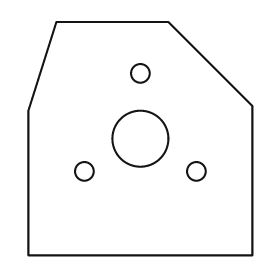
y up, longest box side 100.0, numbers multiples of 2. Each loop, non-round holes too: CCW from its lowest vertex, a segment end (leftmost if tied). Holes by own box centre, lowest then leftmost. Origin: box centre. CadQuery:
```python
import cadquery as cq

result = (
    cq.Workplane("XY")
    .moveTo(-48.0, -50.0)
    .lineTo(48.0, -50.0)
    .lineTo(48.0, 14.0)
    .lineTo(12.0, 50.0)
    .lineTo(-36.0, 50.0)
    .lineTo(-48.0, 12.0)
    .close()
    .moveTo(-24.0, -14.0)
    .circle(4.0)
    .moveTo(24.0, -14.0)
    .circle(4.0)
    .moveTo(0.0, 0.0)
    .circle(12.0)
    .moveTo(0.0, 28.0)
    .circle(4.0)
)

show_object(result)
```